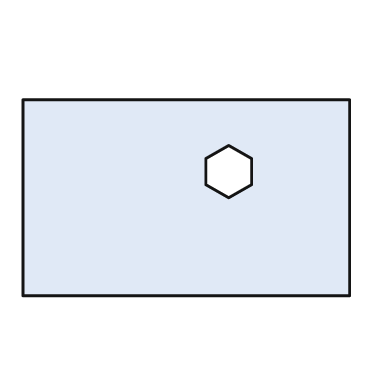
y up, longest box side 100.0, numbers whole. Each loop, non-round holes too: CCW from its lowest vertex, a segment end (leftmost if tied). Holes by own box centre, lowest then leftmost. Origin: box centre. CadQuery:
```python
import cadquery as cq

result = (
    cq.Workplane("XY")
    .moveTo(-50.0, -30.0)
    .lineTo(50.0, -30.0)
    .lineTo(50.0, 30.0)
    .lineTo(-50.0, 30.0)
    .close()
    .moveTo(13.0, 0.0)
    .lineTo(20.0, 4.0)
    .lineTo(20.0, 12.0)
    .lineTo(13.0, 16.0)
    .lineTo(6.0, 12.0)
    .lineTo(6.0, 4.0)
    .close()
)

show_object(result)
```